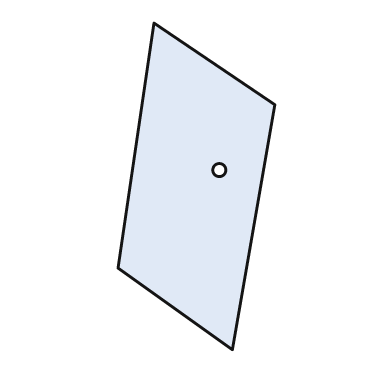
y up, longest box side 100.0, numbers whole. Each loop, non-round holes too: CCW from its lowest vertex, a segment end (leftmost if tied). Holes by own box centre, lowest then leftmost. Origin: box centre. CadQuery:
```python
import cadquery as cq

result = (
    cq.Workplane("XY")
    .moveTo(11.0, -50.0)
    .lineTo(24.0, 25.0)
    .lineTo(-13.0, 50.0)
    .lineTo(-24.0, -25.0)
    .close()
    .moveTo(7.0, 5.0)
    .circle(2.0)
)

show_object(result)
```